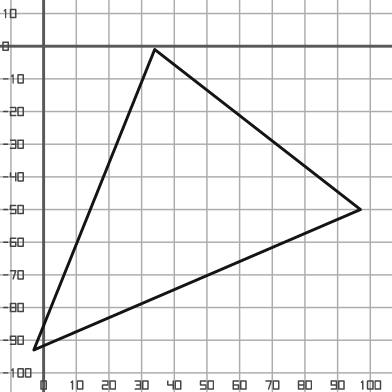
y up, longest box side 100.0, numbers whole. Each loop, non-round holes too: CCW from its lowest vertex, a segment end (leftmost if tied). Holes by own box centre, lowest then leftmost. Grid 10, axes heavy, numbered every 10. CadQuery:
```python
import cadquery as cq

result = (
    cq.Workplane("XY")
    .moveTo(-3.0, -93.0)
    .lineTo(97.0, -50.0)
    .lineTo(34.0, -1.0)
    .close()
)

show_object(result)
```